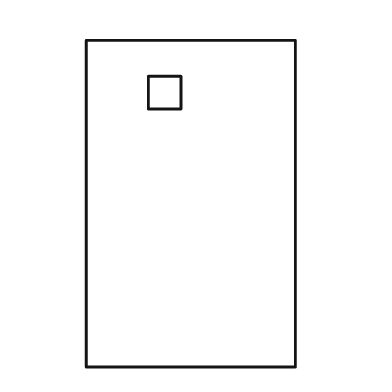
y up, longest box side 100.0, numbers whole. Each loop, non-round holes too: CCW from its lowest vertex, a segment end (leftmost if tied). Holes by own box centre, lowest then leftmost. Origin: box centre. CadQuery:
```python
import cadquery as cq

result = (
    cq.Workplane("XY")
    .moveTo(-32.0, -50.0)
    .lineTo(32.0, -50.0)
    .lineTo(32.0, 50.0)
    .lineTo(-32.0, 50.0)
    .close()
    .moveTo(-13.0, 29.0)
    .lineTo(-3.0, 29.0)
    .lineTo(-3.0, 39.0)
    .lineTo(-13.0, 39.0)
    .close()
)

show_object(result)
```